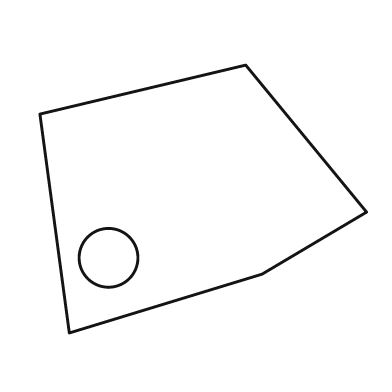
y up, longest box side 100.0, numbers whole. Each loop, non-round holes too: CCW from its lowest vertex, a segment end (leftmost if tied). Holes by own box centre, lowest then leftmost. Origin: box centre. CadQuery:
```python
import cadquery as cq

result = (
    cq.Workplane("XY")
    .moveTo(-41.0, -41.0)
    .lineTo(18.0, -23.0)
    .lineTo(50.0, -4.0)
    .lineTo(13.0, 41.0)
    .lineTo(-50.0, 26.0)
    .close()
    .moveTo(-29.0, -18.0)
    .circle(9.0)
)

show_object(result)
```